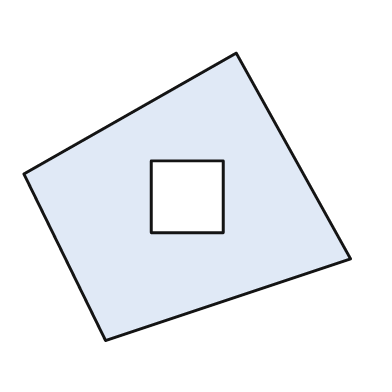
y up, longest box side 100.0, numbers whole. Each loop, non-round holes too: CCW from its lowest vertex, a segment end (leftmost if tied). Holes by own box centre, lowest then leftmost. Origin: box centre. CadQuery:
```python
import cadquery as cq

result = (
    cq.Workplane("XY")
    .moveTo(-25.0, -44.0)
    .lineTo(50.0, -19.0)
    .lineTo(15.0, 44.0)
    .lineTo(-50.0, 7.0)
    .close()
    .moveTo(-11.0, -11.0)
    .lineTo(11.0, -11.0)
    .lineTo(11.0, 11.0)
    .lineTo(-11.0, 11.0)
    .close()
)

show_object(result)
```